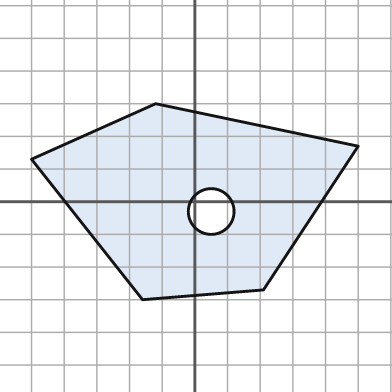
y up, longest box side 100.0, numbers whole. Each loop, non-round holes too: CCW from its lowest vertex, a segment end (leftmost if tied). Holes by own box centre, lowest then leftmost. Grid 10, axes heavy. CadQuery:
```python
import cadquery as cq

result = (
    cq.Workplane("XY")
    .moveTo(-16.0, -30.0)
    .lineTo(21.0, -27.0)
    .lineTo(50.0, 17.0)
    .lineTo(-12.0, 30.0)
    .lineTo(-50.0, 13.0)
    .close()
    .moveTo(5.0, -3.0)
    .circle(7.0)
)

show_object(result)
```